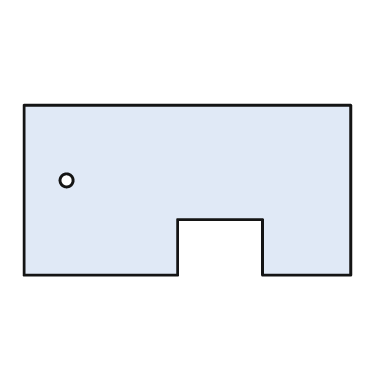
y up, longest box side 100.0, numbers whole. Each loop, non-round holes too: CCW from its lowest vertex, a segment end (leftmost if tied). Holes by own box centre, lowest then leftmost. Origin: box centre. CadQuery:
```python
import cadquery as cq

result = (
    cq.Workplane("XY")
    .moveTo(-50.0, -26.0)
    .lineTo(-3.0, -26.0)
    .lineTo(-3.0, -9.0)
    .lineTo(23.0, -9.0)
    .lineTo(23.0, -26.0)
    .lineTo(50.0, -26.0)
    .lineTo(50.0, 26.0)
    .lineTo(-50.0, 26.0)
    .close()
    .moveTo(-37.0, 3.0)
    .circle(2.0)
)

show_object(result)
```